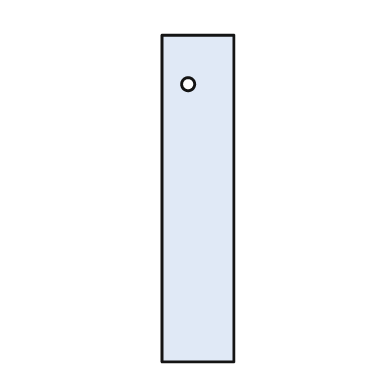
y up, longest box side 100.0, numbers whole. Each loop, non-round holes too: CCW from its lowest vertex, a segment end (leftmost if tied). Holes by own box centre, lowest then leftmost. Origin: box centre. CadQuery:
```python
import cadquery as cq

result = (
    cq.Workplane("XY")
    .moveTo(-11.0, -50.0)
    .lineTo(11.0, -50.0)
    .lineTo(11.0, 50.0)
    .lineTo(-11.0, 50.0)
    .close()
    .moveTo(-3.0, 35.0)
    .circle(2.0)
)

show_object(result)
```